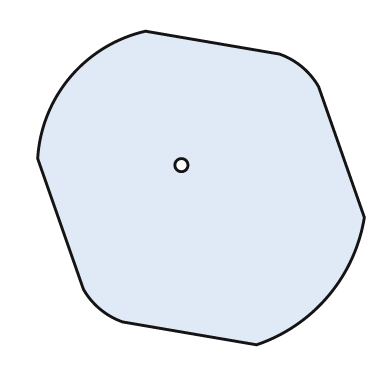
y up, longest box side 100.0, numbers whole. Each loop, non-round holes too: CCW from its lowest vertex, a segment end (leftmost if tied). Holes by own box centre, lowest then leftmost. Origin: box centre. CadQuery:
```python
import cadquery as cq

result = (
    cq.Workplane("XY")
    .moveTo(17.0, -48.0)
    .threePointArc((39.0, -33.0), (50.0, -9.0))
    .lineTo(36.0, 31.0)
    .threePointArc((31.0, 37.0), (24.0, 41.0))
    .lineTo(-17.0, 48.0)
    .threePointArc((-40.0, 34.0), (-50.0, 9.0))
    .lineTo(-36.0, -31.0)
    .threePointArc((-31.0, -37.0), (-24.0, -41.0))
    .close()
    .moveTo(-6.0, 7.0)
    .circle(2.0)
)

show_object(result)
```